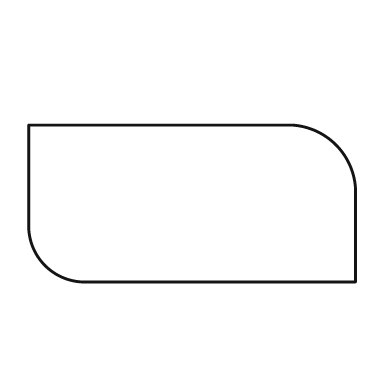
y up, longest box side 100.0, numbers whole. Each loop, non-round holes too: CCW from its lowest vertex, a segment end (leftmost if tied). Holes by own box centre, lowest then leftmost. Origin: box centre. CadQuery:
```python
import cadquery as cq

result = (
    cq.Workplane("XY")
    .moveTo(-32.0, -24.0)
    .lineTo(50.0, -24.0)
    .lineTo(50.0, 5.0)
    .threePointArc((44.0, 18.0), (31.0, 24.0))
    .lineTo(-50.0, 24.0)
    .lineTo(-50.0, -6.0)
    .threePointArc((-45.0, -19.0), (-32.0, -24.0))
    .close()
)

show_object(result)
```